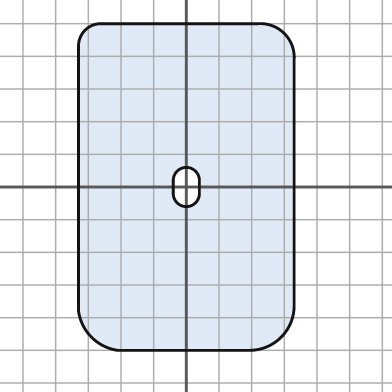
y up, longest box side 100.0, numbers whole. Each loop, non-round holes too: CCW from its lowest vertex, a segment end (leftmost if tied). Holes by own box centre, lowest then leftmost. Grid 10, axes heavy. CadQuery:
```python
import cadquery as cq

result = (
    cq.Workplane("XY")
    .moveTo(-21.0, -50.0)
    .lineTo(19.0, -50.0)
    .threePointArc((29.0, -46.0), (33.0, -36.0))
    .lineTo(33.0, 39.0)
    .threePointArc((30.0, 47.0), (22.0, 50.0))
    .lineTo(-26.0, 50.0)
    .threePointArc((-31.0, 48.0), (-33.0, 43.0))
    .lineTo(-33.0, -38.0)
    .threePointArc((-29.0, -46.0), (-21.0, -50.0))
    .close()
    .moveTo(-4.0, -2.0)
    .threePointArc((0.0, -6.0), (4.0, -2.0))
    .lineTo(4.0, 2.0)
    .threePointArc((0.0, 6.0), (-4.0, 2.0))
    .close()
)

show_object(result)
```